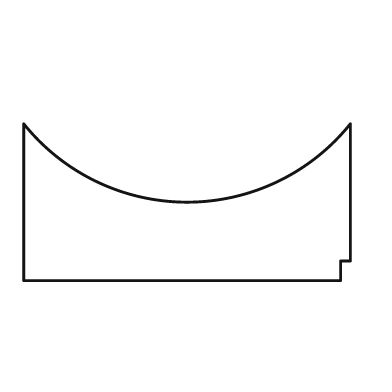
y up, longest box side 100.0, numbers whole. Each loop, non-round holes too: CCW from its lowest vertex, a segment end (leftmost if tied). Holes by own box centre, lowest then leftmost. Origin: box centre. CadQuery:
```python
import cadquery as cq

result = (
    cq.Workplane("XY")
    .moveTo(-50.0, -24.0)
    .lineTo(47.0, -24.0)
    .lineTo(47.0, -18.0)
    .lineTo(50.0, -18.0)
    .lineTo(50.0, 24.0)
    .threePointArc((0.0, 0.0), (-50.0, 24.0))
    .close()
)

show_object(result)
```